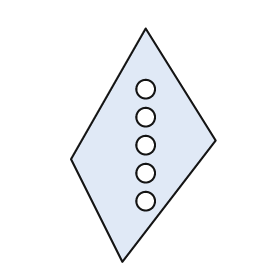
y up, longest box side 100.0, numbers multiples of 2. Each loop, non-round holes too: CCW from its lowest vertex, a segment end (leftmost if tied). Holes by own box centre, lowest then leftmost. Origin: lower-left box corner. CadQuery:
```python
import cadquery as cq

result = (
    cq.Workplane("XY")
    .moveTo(22.0, 0.0)
    .lineTo(62.0, 52.0)
    .lineTo(32.0, 100.0)
    .lineTo(0.0, 44.0)
    .close()
    .moveTo(32.0, 26.0)
    .circle(4.0)
    .moveTo(32.0, 38.0)
    .circle(4.0)
    .moveTo(32.0, 50.0)
    .circle(4.0)
    .moveTo(32.0, 62.0)
    .circle(4.0)
    .moveTo(32.0, 74.0)
    .circle(4.0)
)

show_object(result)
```